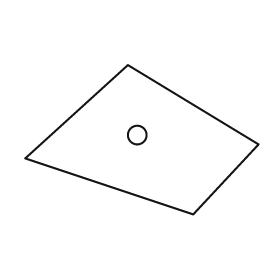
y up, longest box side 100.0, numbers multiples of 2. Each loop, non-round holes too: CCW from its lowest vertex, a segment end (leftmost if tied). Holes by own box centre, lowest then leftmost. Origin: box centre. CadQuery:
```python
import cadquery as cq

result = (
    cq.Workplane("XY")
    .moveTo(22.0, -32.0)
    .lineTo(50.0, -2.0)
    .lineTo(-6.0, 32.0)
    .lineTo(-50.0, -8.0)
    .close()
    .moveTo(-2.0, 2.0)
    .circle(4.0)
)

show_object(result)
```